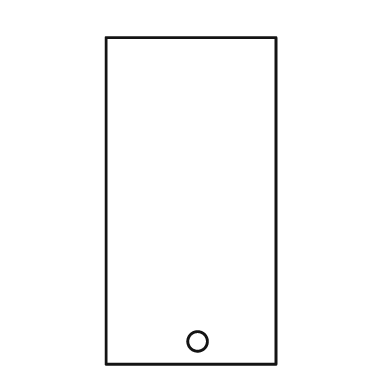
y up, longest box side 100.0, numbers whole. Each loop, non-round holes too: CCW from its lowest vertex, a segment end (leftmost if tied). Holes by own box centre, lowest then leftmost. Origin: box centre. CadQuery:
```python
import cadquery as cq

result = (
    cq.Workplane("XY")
    .moveTo(-26.0, -50.0)
    .lineTo(26.0, -50.0)
    .lineTo(26.0, 50.0)
    .lineTo(-26.0, 50.0)
    .close()
    .moveTo(2.0, -43.0)
    .circle(3.0)
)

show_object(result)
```